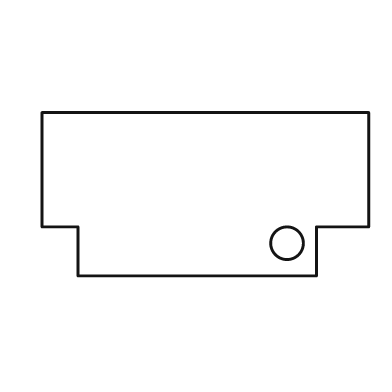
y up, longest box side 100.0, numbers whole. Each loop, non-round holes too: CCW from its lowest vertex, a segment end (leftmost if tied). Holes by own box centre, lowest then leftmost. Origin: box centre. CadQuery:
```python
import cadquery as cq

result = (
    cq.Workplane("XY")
    .moveTo(-39.0, -25.0)
    .lineTo(34.0, -25.0)
    .lineTo(34.0, -10.0)
    .lineTo(50.0, -10.0)
    .lineTo(50.0, 25.0)
    .lineTo(-50.0, 25.0)
    .lineTo(-50.0, -10.0)
    .lineTo(-39.0, -10.0)
    .close()
    .moveTo(25.0, -15.0)
    .circle(5.0)
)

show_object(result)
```